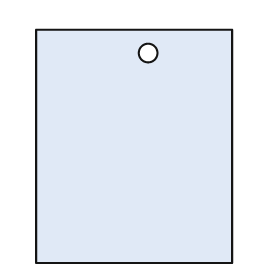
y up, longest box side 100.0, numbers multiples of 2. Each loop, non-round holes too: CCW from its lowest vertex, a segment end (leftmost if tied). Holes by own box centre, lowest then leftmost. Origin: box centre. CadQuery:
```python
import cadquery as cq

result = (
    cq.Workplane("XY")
    .moveTo(-42.0, -50.0)
    .lineTo(42.0, -50.0)
    .lineTo(42.0, 50.0)
    .lineTo(-42.0, 50.0)
    .close()
    .moveTo(6.0, 40.0)
    .circle(4.0)
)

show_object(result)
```